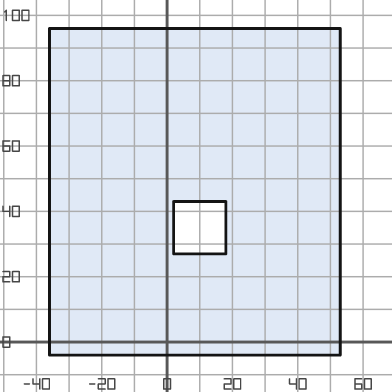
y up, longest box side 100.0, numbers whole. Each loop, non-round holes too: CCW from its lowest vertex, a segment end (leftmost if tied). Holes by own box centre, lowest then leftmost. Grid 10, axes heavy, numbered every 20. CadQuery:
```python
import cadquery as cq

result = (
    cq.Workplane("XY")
    .moveTo(-36.0, -4.0)
    .lineTo(53.0, -4.0)
    .lineTo(53.0, 96.0)
    .lineTo(-36.0, 96.0)
    .close()
    .moveTo(2.0, 27.0)
    .lineTo(18.0, 27.0)
    .lineTo(18.0, 43.0)
    .lineTo(2.0, 43.0)
    .close()
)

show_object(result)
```